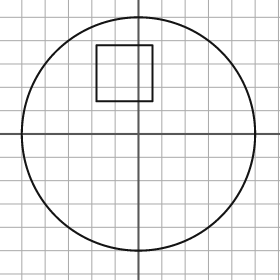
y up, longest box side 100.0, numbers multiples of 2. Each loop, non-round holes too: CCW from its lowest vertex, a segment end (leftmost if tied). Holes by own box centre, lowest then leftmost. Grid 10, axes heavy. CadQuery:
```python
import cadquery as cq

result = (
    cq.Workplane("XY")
    .moveTo(0.0, 0.0)
    .circle(50.0)
    .moveTo(-18.0, 14.0)
    .lineTo(6.0, 14.0)
    .lineTo(6.0, 38.0)
    .lineTo(-18.0, 38.0)
    .close()
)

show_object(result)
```